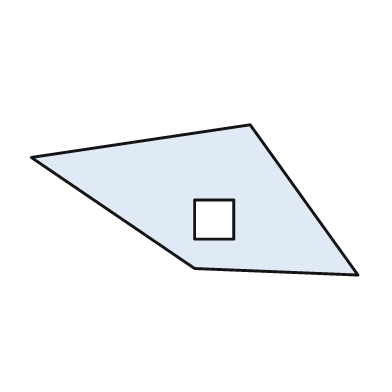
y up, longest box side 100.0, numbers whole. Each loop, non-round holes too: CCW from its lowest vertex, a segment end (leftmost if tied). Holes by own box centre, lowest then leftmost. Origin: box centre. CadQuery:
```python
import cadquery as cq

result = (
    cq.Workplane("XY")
    .moveTo(50.0, -23.0)
    .lineTo(17.0, 23.0)
    .lineTo(-50.0, 13.0)
    .lineTo(0.0, -21.0)
    .close()
    .moveTo(0.0, -12.0)
    .lineTo(12.0, -12.0)
    .lineTo(12.0, 0.0)
    .lineTo(0.0, 0.0)
    .close()
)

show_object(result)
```